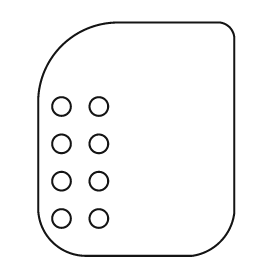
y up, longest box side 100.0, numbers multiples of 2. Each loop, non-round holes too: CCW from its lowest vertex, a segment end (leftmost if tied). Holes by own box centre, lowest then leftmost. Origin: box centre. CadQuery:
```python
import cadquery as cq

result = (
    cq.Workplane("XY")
    .moveTo(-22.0, -50.0)
    .lineTo(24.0, -50.0)
    .threePointArc((36.0, -44.0), (42.0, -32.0))
    .lineTo(42.0, 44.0)
    .threePointArc((40.0, 48.0), (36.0, 50.0))
    .lineTo(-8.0, 50.0)
    .threePointArc((-32.0, 40.0), (-42.0, 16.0))
    .lineTo(-42.0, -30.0)
    .threePointArc((-36.0, -44.0), (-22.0, -50.0))
    .close()
    .moveTo(-32.0, -34.0)
    .circle(4.0)
    .moveTo(-16.0, -34.0)
    .circle(4.0)
    .moveTo(-32.0, -18.0)
    .circle(4.0)
    .moveTo(-16.0, -18.0)
    .circle(4.0)
    .moveTo(-32.0, -2.0)
    .circle(4.0)
    .moveTo(-16.0, -2.0)
    .circle(4.0)
    .moveTo(-32.0, 14.0)
    .circle(4.0)
    .moveTo(-16.0, 14.0)
    .circle(4.0)
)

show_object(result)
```